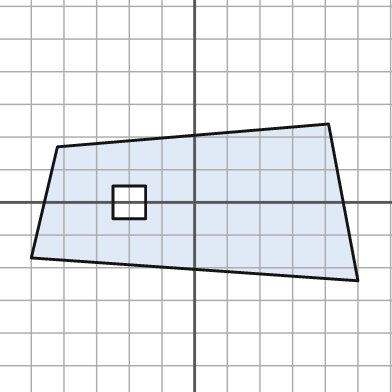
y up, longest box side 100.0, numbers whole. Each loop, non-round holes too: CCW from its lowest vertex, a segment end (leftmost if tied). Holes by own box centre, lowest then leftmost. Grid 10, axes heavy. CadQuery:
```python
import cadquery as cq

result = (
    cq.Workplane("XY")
    .moveTo(50.0, -24.0)
    .lineTo(41.0, 24.0)
    .lineTo(-42.0, 17.0)
    .lineTo(-50.0, -17.0)
    .close()
    .moveTo(-25.0, -5.0)
    .lineTo(-15.0, -5.0)
    .lineTo(-15.0, 5.0)
    .lineTo(-25.0, 5.0)
    .close()
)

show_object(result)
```